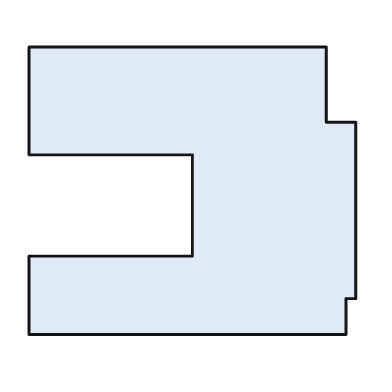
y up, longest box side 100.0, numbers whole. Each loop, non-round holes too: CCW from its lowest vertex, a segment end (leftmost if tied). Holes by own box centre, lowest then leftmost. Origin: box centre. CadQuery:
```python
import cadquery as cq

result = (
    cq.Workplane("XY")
    .moveTo(-50.0, -44.0)
    .lineTo(47.0, -44.0)
    .lineTo(47.0, -33.0)
    .lineTo(50.0, -33.0)
    .lineTo(50.0, 21.0)
    .lineTo(41.0, 21.0)
    .lineTo(41.0, 44.0)
    .lineTo(-50.0, 44.0)
    .lineTo(-50.0, 11.0)
    .lineTo(0.0, 11.0)
    .lineTo(0.0, -20.0)
    .lineTo(-50.0, -20.0)
    .close()
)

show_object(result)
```